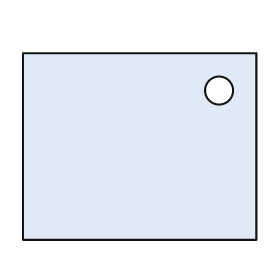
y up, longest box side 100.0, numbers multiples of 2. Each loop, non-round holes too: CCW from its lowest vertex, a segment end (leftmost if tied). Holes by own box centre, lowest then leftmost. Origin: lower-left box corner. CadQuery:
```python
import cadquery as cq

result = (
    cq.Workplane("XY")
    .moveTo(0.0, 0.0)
    .lineTo(100.0, 0.0)
    .lineTo(100.0, 80.0)
    .lineTo(0.0, 80.0)
    .close()
    .moveTo(84.0, 64.0)
    .circle(6.0)
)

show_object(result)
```